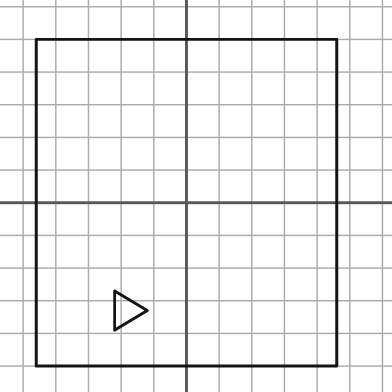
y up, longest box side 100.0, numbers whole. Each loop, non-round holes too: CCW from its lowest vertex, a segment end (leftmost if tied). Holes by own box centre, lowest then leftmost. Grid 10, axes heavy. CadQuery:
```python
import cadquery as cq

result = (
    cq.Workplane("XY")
    .moveTo(-46.0, -50.0)
    .lineTo(46.0, -50.0)
    .lineTo(46.0, 50.0)
    .lineTo(-46.0, 50.0)
    .close()
    .moveTo(-22.0, -39.0)
    .lineTo(-12.0, -33.0)
    .lineTo(-22.0, -27.0)
    .close()
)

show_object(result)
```